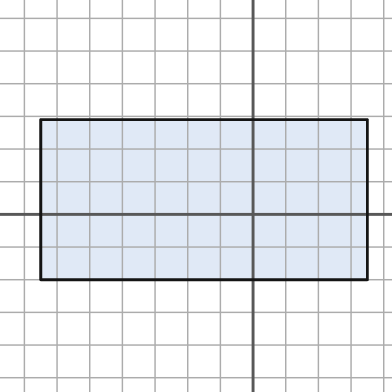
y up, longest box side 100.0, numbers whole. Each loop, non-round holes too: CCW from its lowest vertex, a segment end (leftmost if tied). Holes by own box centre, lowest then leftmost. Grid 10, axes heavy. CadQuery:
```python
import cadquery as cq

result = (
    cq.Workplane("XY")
    .moveTo(-65.0, -20.0)
    .lineTo(35.0, -20.0)
    .lineTo(35.0, 29.0)
    .lineTo(-65.0, 29.0)
    .close()
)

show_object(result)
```